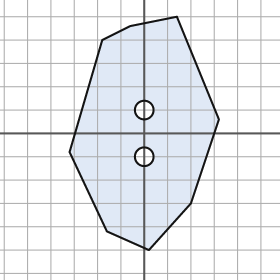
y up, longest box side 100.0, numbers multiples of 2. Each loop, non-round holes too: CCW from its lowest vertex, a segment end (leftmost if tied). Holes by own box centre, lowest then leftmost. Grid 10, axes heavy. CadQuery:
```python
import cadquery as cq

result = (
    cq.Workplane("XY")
    .moveTo(2.0, -50.0)
    .lineTo(20.0, -30.0)
    .lineTo(32.0, 6.0)
    .lineTo(14.0, 50.0)
    .lineTo(-6.0, 46.0)
    .lineTo(-18.0, 40.0)
    .lineTo(-32.0, -8.0)
    .lineTo(-16.0, -42.0)
    .close()
    .moveTo(0.0, -10.0)
    .circle(4.0)
    .moveTo(0.0, 10.0)
    .circle(4.0)
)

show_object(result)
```